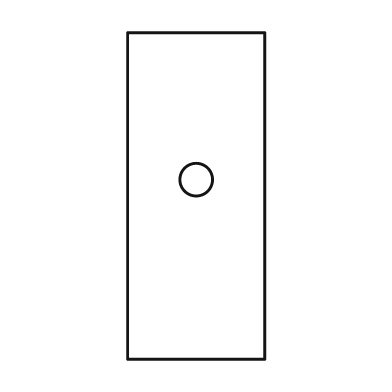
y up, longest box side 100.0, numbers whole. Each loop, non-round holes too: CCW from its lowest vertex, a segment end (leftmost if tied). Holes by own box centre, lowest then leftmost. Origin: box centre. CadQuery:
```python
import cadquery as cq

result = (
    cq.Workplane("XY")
    .moveTo(-21.0, -50.0)
    .lineTo(21.0, -50.0)
    .lineTo(21.0, 50.0)
    .lineTo(-21.0, 50.0)
    .close()
    .moveTo(0.0, 5.0)
    .circle(5.0)
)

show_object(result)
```